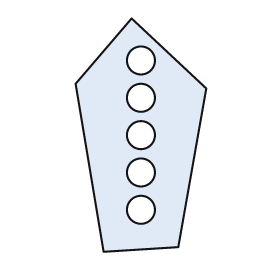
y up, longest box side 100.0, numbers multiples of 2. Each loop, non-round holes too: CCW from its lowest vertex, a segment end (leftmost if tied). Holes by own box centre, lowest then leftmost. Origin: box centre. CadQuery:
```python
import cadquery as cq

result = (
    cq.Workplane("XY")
    .moveTo(-16.0, -50.0)
    .lineTo(16.0, -48.0)
    .lineTo(28.0, 20.0)
    .lineTo(-4.0, 50.0)
    .lineTo(-28.0, 22.0)
    .close()
    .moveTo(0.0, -32.0)
    .circle(6.0)
    .moveTo(0.0, -16.0)
    .circle(6.0)
    .moveTo(0.0, 0.0)
    .circle(6.0)
    .moveTo(0.0, 16.0)
    .circle(6.0)
    .moveTo(0.0, 32.0)
    .circle(6.0)
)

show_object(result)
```